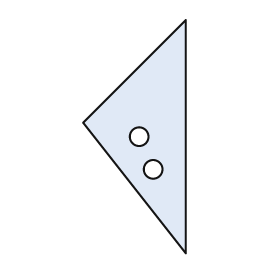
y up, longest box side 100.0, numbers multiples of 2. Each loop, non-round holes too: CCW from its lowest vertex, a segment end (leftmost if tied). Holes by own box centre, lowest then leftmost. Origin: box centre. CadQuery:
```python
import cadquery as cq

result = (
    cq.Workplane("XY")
    .moveTo(22.0, -50.0)
    .lineTo(22.0, 50.0)
    .lineTo(-22.0, 6.0)
    .close()
    .moveTo(8.0, -14.0)
    .circle(4.0)
    .moveTo(2.0, 0.0)
    .circle(4.0)
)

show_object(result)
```